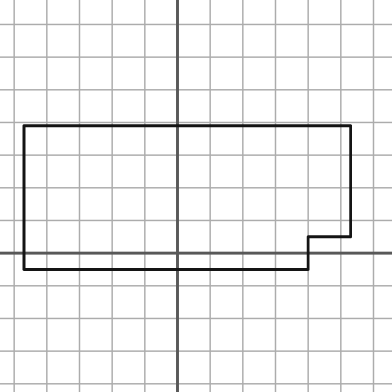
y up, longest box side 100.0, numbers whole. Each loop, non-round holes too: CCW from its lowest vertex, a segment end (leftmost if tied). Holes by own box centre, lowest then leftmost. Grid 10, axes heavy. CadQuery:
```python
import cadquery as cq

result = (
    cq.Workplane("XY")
    .moveTo(-47.0, -5.0)
    .lineTo(40.0, -5.0)
    .lineTo(40.0, 5.0)
    .lineTo(53.0, 5.0)
    .lineTo(53.0, 39.0)
    .lineTo(-47.0, 39.0)
    .close()
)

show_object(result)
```